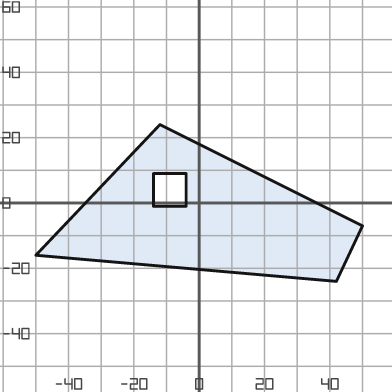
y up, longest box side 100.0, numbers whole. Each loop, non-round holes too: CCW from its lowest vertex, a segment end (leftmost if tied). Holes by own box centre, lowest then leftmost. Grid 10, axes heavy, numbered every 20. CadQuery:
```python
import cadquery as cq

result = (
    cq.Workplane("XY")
    .moveTo(42.0, -24.0)
    .lineTo(50.0, -7.0)
    .lineTo(-12.0, 24.0)
    .lineTo(-50.0, -16.0)
    .close()
    .moveTo(-14.0, -1.0)
    .lineTo(-4.0, -1.0)
    .lineTo(-4.0, 9.0)
    .lineTo(-14.0, 9.0)
    .close()
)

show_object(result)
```